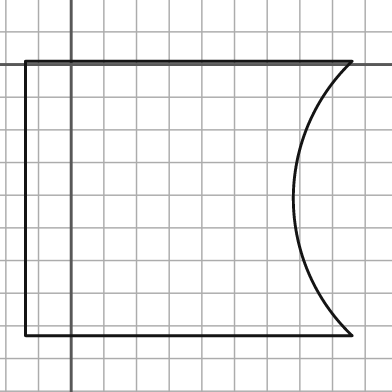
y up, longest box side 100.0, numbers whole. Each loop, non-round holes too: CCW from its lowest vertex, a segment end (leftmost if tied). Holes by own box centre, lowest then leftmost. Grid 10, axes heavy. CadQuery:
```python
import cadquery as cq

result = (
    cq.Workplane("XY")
    .moveTo(-14.0, -83.0)
    .lineTo(86.0, -83.0)
    .threePointArc((68.0, -41.0), (86.0, 1.0))
    .lineTo(-14.0, 1.0)
    .close()
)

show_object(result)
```